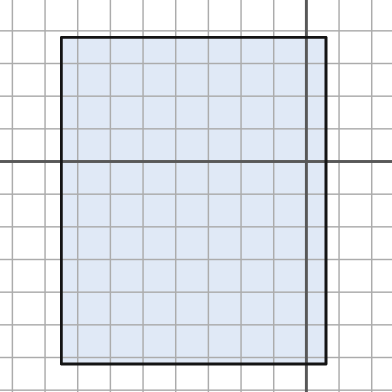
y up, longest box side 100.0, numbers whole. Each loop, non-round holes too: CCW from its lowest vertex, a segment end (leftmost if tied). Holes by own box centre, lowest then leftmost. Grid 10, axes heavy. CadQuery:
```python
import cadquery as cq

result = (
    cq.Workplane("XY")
    .moveTo(-75.0, -62.0)
    .lineTo(6.0, -62.0)
    .lineTo(6.0, 38.0)
    .lineTo(-75.0, 38.0)
    .close()
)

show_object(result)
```